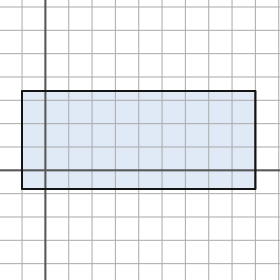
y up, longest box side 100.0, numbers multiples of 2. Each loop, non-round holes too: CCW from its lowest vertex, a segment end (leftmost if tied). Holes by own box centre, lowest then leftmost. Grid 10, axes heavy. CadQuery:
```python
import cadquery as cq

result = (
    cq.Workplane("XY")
    .moveTo(-10.0, -8.0)
    .lineTo(90.0, -8.0)
    .lineTo(90.0, 34.0)
    .lineTo(-10.0, 34.0)
    .close()
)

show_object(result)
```